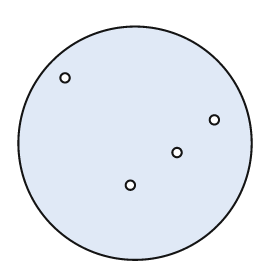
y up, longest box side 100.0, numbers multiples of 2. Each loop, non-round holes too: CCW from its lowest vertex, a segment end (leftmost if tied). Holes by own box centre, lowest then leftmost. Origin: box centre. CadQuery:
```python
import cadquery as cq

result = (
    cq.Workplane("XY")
    .moveTo(0.0, 0.0)
    .circle(50.0)
    .moveTo(-2.0, -18.0)
    .circle(2.0)
    .moveTo(18.0, -4.0)
    .circle(2.0)
    .moveTo(34.0, 10.0)
    .circle(2.0)
    .moveTo(-30.0, 28.0)
    .circle(2.0)
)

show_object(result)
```